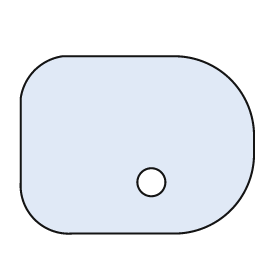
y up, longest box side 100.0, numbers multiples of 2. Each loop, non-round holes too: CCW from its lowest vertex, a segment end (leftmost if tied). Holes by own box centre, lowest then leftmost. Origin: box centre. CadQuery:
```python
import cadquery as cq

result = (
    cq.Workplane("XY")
    .moveTo(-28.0, -38.0)
    .lineTo(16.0, -38.0)
    .threePointArc((40.0, -28.0), (50.0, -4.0))
    .lineTo(50.0, 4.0)
    .threePointArc((40.0, 28.0), (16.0, 38.0))
    .lineTo(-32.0, 38.0)
    .threePointArc((-44.0, 32.0), (-50.0, 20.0))
    .lineTo(-50.0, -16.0)
    .threePointArc((-44.0, -32.0), (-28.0, -38.0))
    .close()
    .moveTo(6.0, -16.0)
    .circle(6.0)
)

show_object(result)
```